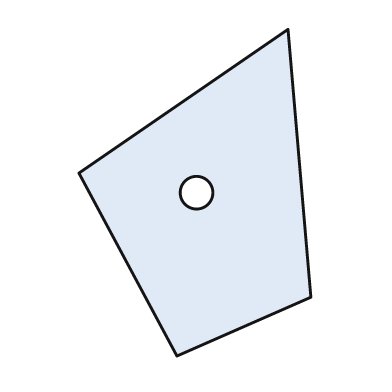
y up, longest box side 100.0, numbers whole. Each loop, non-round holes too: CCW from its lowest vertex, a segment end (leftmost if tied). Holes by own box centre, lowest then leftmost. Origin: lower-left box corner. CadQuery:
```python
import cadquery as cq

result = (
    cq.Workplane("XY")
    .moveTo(30.0, 0.0)
    .lineTo(71.0, 18.0)
    .lineTo(64.0, 100.0)
    .lineTo(0.0, 56.0)
    .close()
    .moveTo(36.0, 50.0)
    .circle(5.0)
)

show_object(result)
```